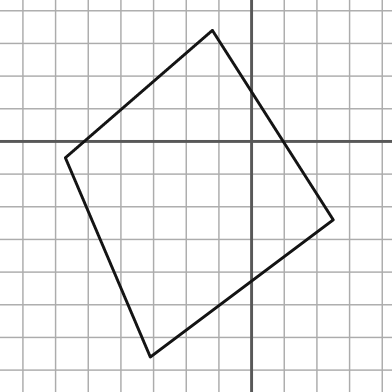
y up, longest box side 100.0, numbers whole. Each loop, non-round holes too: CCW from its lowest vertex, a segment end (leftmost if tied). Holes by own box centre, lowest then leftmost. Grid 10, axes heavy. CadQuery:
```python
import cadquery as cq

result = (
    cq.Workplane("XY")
    .moveTo(-31.0, -66.0)
    .lineTo(25.0, -24.0)
    .lineTo(-12.0, 34.0)
    .lineTo(-57.0, -5.0)
    .close()
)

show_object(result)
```